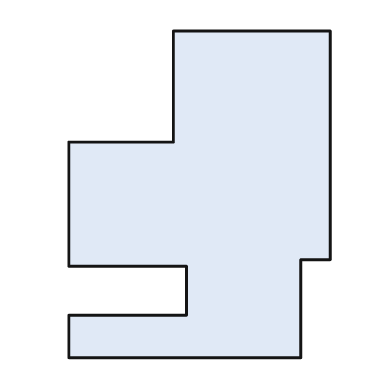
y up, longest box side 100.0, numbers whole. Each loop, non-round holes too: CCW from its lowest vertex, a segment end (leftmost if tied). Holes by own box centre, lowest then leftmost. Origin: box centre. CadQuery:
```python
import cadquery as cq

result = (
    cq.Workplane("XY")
    .moveTo(-40.0, -50.0)
    .lineTo(31.0, -50.0)
    .lineTo(31.0, -20.0)
    .lineTo(40.0, -20.0)
    .lineTo(40.0, 50.0)
    .lineTo(-8.0, 50.0)
    .lineTo(-8.0, 16.0)
    .lineTo(-40.0, 16.0)
    .lineTo(-40.0, -22.0)
    .lineTo(-4.0, -22.0)
    .lineTo(-4.0, -37.0)
    .lineTo(-40.0, -37.0)
    .close()
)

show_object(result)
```